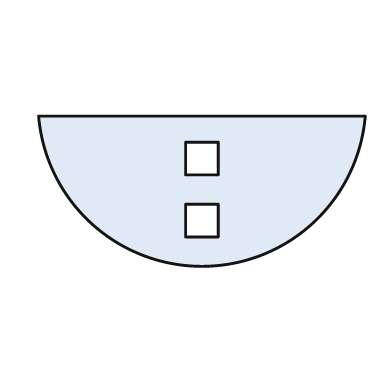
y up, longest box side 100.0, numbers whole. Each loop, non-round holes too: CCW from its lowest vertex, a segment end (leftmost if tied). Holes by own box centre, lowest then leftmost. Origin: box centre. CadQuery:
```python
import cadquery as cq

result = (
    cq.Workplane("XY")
    .moveTo(-50.0, 23.0)
    .threePointArc((0.0, -23.0), (50.0, 23.0))
    .close()
    .moveTo(-5.0, -14.0)
    .lineTo(5.0, -14.0)
    .lineTo(5.0, -4.0)
    .lineTo(-5.0, -4.0)
    .close()
    .moveTo(-5.0, 5.0)
    .lineTo(5.0, 5.0)
    .lineTo(5.0, 15.0)
    .lineTo(-5.0, 15.0)
    .close()
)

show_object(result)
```